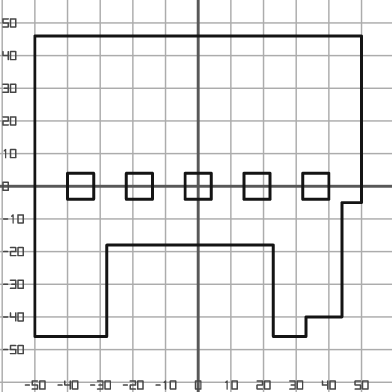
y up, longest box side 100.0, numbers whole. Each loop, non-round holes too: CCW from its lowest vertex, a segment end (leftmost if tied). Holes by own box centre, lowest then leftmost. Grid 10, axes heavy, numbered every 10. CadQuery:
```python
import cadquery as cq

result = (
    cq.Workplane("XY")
    .moveTo(-50.0, -46.0)
    .lineTo(-28.0, -46.0)
    .lineTo(-28.0, -18.0)
    .lineTo(23.0, -18.0)
    .lineTo(23.0, -46.0)
    .lineTo(33.0, -46.0)
    .lineTo(33.0, -40.0)
    .lineTo(44.0, -40.0)
    .lineTo(44.0, -5.0)
    .lineTo(50.0, -5.0)
    .lineTo(50.0, 46.0)
    .lineTo(-50.0, 46.0)
    .close()
    .moveTo(-40.0, -4.0)
    .lineTo(-32.0, -4.0)
    .lineTo(-32.0, 4.0)
    .lineTo(-40.0, 4.0)
    .close()
    .moveTo(-22.0, -4.0)
    .lineTo(-14.0, -4.0)
    .lineTo(-14.0, 4.0)
    .lineTo(-22.0, 4.0)
    .close()
    .moveTo(-4.0, -4.0)
    .lineTo(4.0, -4.0)
    .lineTo(4.0, 4.0)
    .lineTo(-4.0, 4.0)
    .close()
    .moveTo(14.0, -4.0)
    .lineTo(22.0, -4.0)
    .lineTo(22.0, 4.0)
    .lineTo(14.0, 4.0)
    .close()
    .moveTo(32.0, -4.0)
    .lineTo(40.0, -4.0)
    .lineTo(40.0, 4.0)
    .lineTo(32.0, 4.0)
    .close()
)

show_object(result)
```